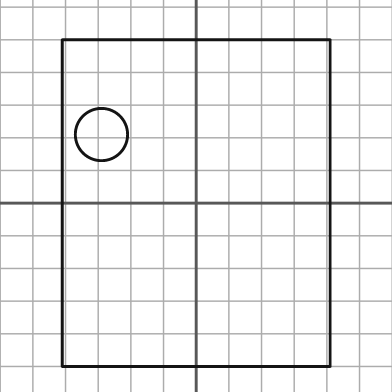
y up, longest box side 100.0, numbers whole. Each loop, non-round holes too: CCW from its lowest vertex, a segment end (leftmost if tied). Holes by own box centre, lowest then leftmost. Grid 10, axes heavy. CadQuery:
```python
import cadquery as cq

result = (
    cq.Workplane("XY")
    .moveTo(-41.0, -50.0)
    .lineTo(41.0, -50.0)
    .lineTo(41.0, 50.0)
    .lineTo(-41.0, 50.0)
    .close()
    .moveTo(-29.0, 21.0)
    .circle(8.0)
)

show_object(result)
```